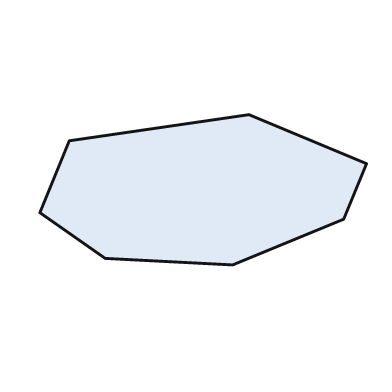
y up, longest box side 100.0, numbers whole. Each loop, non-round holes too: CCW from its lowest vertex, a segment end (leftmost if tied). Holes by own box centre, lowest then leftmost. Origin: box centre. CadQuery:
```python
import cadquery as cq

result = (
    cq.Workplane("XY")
    .moveTo(9.0, -23.0)
    .lineTo(43.0, -9.0)
    .lineTo(50.0, 8.0)
    .lineTo(14.0, 23.0)
    .lineTo(-41.0, 15.0)
    .lineTo(-50.0, -7.0)
    .lineTo(-30.0, -21.0)
    .close()
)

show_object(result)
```